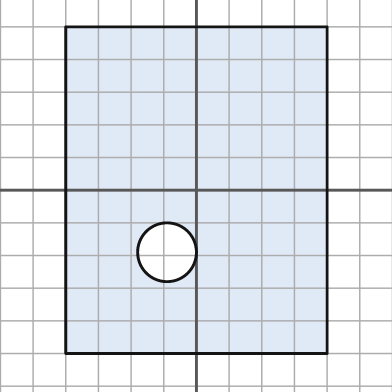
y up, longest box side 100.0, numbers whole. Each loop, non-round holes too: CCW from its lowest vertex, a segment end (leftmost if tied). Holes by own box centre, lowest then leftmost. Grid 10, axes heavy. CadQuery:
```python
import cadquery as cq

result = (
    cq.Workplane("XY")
    .moveTo(-40.0, -50.0)
    .lineTo(40.0, -50.0)
    .lineTo(40.0, 50.0)
    .lineTo(-40.0, 50.0)
    .close()
    .moveTo(-9.0, -19.0)
    .circle(9.0)
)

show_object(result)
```